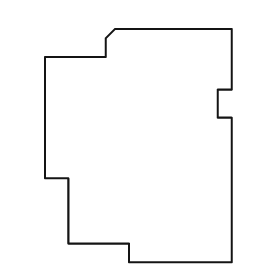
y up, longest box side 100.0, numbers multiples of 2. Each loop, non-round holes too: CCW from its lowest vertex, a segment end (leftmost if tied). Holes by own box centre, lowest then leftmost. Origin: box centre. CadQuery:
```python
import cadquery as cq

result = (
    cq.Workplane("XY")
    .moveTo(-4.0, -50.0)
    .lineTo(40.0, -50.0)
    .lineTo(40.0, 12.0)
    .lineTo(34.0, 12.0)
    .lineTo(34.0, 24.0)
    .lineTo(40.0, 24.0)
    .lineTo(40.0, 50.0)
    .lineTo(-10.0, 50.0)
    .lineTo(-14.0, 46.0)
    .lineTo(-14.0, 38.0)
    .lineTo(-40.0, 38.0)
    .lineTo(-40.0, -14.0)
    .lineTo(-30.0, -14.0)
    .lineTo(-30.0, -42.0)
    .lineTo(-4.0, -42.0)
    .close()
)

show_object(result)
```